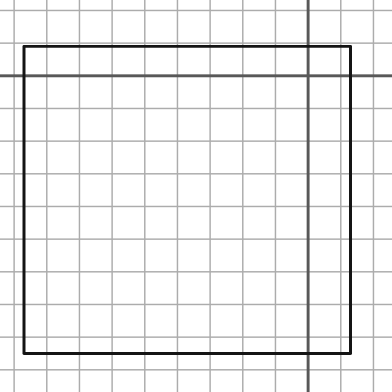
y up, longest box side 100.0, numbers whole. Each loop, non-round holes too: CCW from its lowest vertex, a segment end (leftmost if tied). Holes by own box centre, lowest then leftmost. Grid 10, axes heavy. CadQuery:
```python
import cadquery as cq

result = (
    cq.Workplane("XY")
    .moveTo(-87.0, -85.0)
    .lineTo(13.0, -85.0)
    .lineTo(13.0, 9.0)
    .lineTo(-87.0, 9.0)
    .close()
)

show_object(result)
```